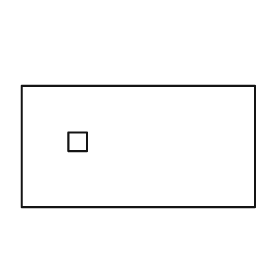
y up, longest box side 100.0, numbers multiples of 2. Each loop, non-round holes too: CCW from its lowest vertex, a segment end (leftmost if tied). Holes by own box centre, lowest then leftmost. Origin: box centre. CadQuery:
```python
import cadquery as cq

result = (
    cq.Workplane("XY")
    .moveTo(-50.0, -26.0)
    .lineTo(50.0, -26.0)
    .lineTo(50.0, 26.0)
    .lineTo(-50.0, 26.0)
    .close()
    .moveTo(-30.0, -2.0)
    .lineTo(-22.0, -2.0)
    .lineTo(-22.0, 6.0)
    .lineTo(-30.0, 6.0)
    .close()
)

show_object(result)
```